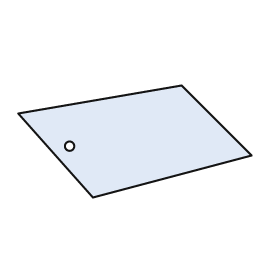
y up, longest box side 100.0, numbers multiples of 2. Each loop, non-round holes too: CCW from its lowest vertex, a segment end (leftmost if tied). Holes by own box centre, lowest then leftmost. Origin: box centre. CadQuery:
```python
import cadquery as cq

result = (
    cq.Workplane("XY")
    .moveTo(-18.0, -24.0)
    .lineTo(50.0, -6.0)
    .lineTo(20.0, 24.0)
    .lineTo(-50.0, 12.0)
    .close()
    .moveTo(-28.0, -2.0)
    .circle(2.0)
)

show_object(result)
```